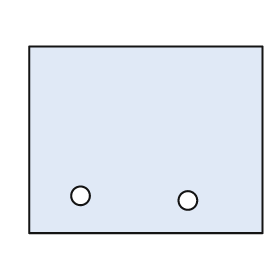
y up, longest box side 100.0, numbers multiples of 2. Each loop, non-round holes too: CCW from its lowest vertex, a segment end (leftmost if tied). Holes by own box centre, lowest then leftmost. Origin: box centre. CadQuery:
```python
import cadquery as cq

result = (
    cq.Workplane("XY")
    .moveTo(-50.0, -40.0)
    .lineTo(50.0, -40.0)
    .lineTo(50.0, 40.0)
    .lineTo(-50.0, 40.0)
    .close()
    .moveTo(18.0, -26.0)
    .circle(4.0)
    .moveTo(-28.0, -24.0)
    .circle(4.0)
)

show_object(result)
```